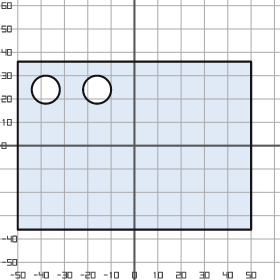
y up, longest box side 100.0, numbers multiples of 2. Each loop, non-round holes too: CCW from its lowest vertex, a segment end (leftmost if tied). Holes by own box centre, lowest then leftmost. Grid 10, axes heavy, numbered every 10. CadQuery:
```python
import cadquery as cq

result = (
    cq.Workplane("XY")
    .moveTo(-50.0, -36.0)
    .lineTo(50.0, -36.0)
    .lineTo(50.0, 36.0)
    .lineTo(-50.0, 36.0)
    .close()
    .moveTo(-38.0, 24.0)
    .circle(6.0)
    .moveTo(-16.0, 24.0)
    .circle(6.0)
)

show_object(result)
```